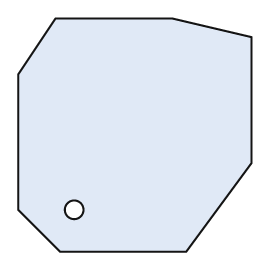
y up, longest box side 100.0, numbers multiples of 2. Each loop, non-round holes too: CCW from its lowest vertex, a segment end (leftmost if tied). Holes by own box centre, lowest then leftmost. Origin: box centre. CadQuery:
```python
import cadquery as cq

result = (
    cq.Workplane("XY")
    .moveTo(-32.0, -50.0)
    .lineTo(22.0, -50.0)
    .lineTo(50.0, -12.0)
    .lineTo(50.0, 42.0)
    .lineTo(16.0, 50.0)
    .lineTo(-34.0, 50.0)
    .lineTo(-50.0, 26.0)
    .lineTo(-50.0, -32.0)
    .close()
    .moveTo(-26.0, -32.0)
    .circle(4.0)
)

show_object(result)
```